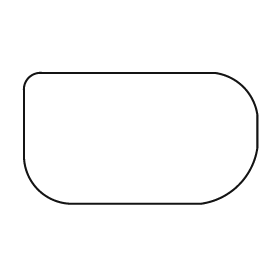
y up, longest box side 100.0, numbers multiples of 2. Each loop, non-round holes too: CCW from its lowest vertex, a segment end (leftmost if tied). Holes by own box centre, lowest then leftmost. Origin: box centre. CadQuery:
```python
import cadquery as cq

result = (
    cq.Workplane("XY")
    .moveTo(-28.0, -28.0)
    .lineTo(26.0, -28.0)
    .threePointArc((42.0, -20.0), (50.0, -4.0))
    .lineTo(50.0, 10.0)
    .threePointArc((44.0, 22.0), (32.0, 28.0))
    .lineTo(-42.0, 28.0)
    .threePointArc((-48.0, 26.0), (-50.0, 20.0))
    .lineTo(-50.0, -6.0)
    .threePointArc((-44.0, -22.0), (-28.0, -28.0))
    .close()
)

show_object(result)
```